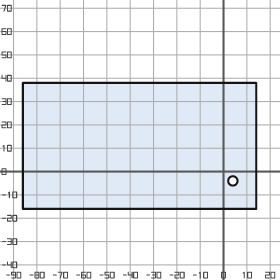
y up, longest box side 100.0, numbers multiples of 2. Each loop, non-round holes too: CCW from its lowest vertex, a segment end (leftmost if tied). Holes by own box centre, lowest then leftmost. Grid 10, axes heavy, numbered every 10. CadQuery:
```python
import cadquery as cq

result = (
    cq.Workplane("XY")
    .moveTo(-86.0, -16.0)
    .lineTo(14.0, -16.0)
    .lineTo(14.0, 38.0)
    .lineTo(-86.0, 38.0)
    .close()
    .moveTo(4.0, -4.0)
    .circle(2.0)
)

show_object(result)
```